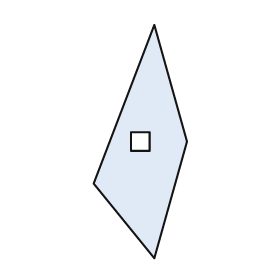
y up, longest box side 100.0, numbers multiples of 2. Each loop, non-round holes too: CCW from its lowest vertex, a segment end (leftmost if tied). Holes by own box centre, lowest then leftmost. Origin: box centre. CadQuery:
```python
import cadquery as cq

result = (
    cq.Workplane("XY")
    .moveTo(6.0, -50.0)
    .lineTo(20.0, 0.0)
    .lineTo(6.0, 50.0)
    .lineTo(-20.0, -18.0)
    .close()
    .moveTo(-4.0, -4.0)
    .lineTo(4.0, -4.0)
    .lineTo(4.0, 4.0)
    .lineTo(-4.0, 4.0)
    .close()
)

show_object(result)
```